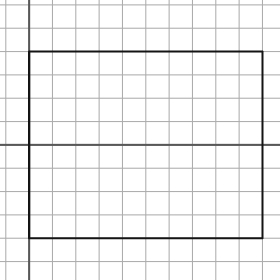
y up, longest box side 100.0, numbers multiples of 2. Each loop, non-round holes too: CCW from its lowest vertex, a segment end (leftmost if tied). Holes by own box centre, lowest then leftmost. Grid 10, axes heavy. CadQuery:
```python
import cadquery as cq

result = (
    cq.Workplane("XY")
    .moveTo(0.0, -40.0)
    .lineTo(100.0, -40.0)
    .lineTo(100.0, 40.0)
    .lineTo(0.0, 40.0)
    .close()
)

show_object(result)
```